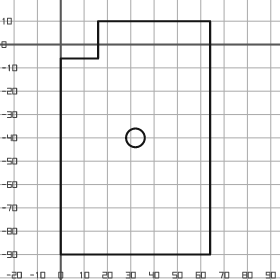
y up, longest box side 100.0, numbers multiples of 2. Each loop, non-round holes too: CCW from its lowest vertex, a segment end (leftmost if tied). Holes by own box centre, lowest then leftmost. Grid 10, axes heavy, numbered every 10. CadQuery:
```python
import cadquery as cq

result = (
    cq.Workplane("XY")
    .moveTo(0.0, -90.0)
    .lineTo(64.0, -90.0)
    .lineTo(64.0, 10.0)
    .lineTo(16.0, 10.0)
    .lineTo(16.0, -6.0)
    .lineTo(0.0, -6.0)
    .close()
    .moveTo(32.0, -40.0)
    .circle(4.0)
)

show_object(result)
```